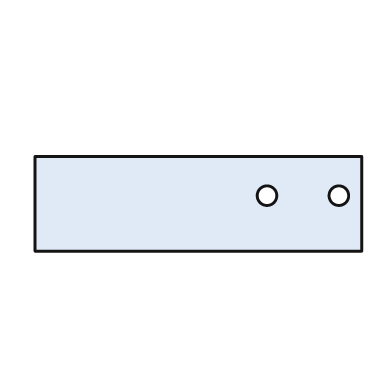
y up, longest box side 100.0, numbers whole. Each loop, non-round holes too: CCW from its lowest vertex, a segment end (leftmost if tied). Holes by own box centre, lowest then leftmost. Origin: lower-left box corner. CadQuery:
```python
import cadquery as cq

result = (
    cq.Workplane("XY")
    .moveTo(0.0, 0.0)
    .lineTo(100.0, 0.0)
    .lineTo(100.0, 29.0)
    .lineTo(0.0, 29.0)
    .close()
    .moveTo(71.0, 17.0)
    .circle(3.0)
    .moveTo(93.0, 17.0)
    .circle(3.0)
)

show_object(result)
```